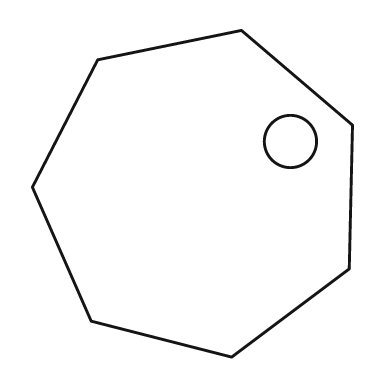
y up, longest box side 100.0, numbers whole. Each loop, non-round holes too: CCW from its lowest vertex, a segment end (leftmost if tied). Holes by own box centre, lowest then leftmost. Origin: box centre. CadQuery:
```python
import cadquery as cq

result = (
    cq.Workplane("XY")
    .moveTo(12.0, -50.0)
    .lineTo(48.0, -23.0)
    .lineTo(49.0, 21.0)
    .lineTo(15.0, 50.0)
    .lineTo(-29.0, 41.0)
    .lineTo(-49.0, 2.0)
    .lineTo(-31.0, -39.0)
    .close()
    .moveTo(30.0, 16.0)
    .circle(8.0)
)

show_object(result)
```